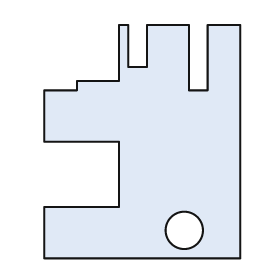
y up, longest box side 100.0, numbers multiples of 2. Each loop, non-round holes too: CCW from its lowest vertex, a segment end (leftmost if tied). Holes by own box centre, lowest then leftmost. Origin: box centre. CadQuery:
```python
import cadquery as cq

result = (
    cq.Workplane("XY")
    .moveTo(-42.0, -50.0)
    .lineTo(42.0, -50.0)
    .lineTo(42.0, 50.0)
    .lineTo(28.0, 50.0)
    .lineTo(28.0, 22.0)
    .lineTo(20.0, 22.0)
    .lineTo(20.0, 50.0)
    .lineTo(2.0, 50.0)
    .lineTo(2.0, 32.0)
    .lineTo(-6.0, 32.0)
    .lineTo(-6.0, 50.0)
    .lineTo(-10.0, 50.0)
    .lineTo(-10.0, 26.0)
    .lineTo(-28.0, 26.0)
    .lineTo(-28.0, 22.0)
    .lineTo(-42.0, 22.0)
    .lineTo(-42.0, 0.0)
    .lineTo(-10.0, 0.0)
    .lineTo(-10.0, -28.0)
    .lineTo(-42.0, -28.0)
    .close()
    .moveTo(18.0, -38.0)
    .circle(8.0)
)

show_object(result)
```